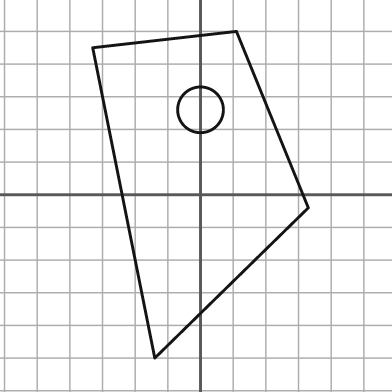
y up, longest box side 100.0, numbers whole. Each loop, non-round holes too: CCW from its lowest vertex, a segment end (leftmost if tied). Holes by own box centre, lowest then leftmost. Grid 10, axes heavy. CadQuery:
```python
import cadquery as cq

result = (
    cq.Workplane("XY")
    .moveTo(-14.0, -50.0)
    .lineTo(33.0, -4.0)
    .lineTo(11.0, 50.0)
    .lineTo(-33.0, 45.0)
    .close()
    .moveTo(0.0, 26.0)
    .circle(7.0)
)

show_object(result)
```